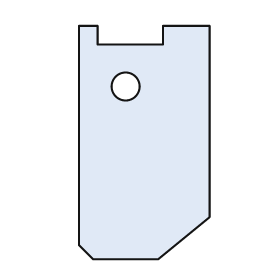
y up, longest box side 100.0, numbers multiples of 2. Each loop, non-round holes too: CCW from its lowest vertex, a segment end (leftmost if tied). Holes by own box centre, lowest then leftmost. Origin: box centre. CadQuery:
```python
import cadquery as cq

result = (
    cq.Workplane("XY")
    .moveTo(-22.0, -50.0)
    .lineTo(6.0, -50.0)
    .lineTo(28.0, -32.0)
    .lineTo(28.0, 50.0)
    .lineTo(8.0, 50.0)
    .lineTo(8.0, 42.0)
    .lineTo(-20.0, 42.0)
    .lineTo(-20.0, 50.0)
    .lineTo(-28.0, 50.0)
    .lineTo(-28.0, -44.0)
    .close()
    .moveTo(-8.0, 24.0)
    .circle(6.0)
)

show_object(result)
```